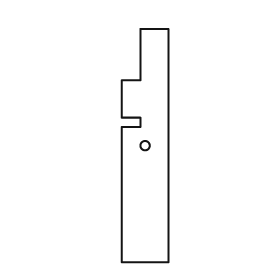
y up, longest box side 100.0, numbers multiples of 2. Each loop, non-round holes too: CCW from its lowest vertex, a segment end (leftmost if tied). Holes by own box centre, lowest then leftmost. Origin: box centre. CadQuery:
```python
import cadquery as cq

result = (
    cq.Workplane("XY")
    .moveTo(-10.0, -50.0)
    .lineTo(10.0, -50.0)
    .lineTo(10.0, 50.0)
    .lineTo(-2.0, 50.0)
    .lineTo(-2.0, 28.0)
    .lineTo(-10.0, 28.0)
    .lineTo(-10.0, 12.0)
    .lineTo(-2.0, 12.0)
    .lineTo(-2.0, 8.0)
    .lineTo(-10.0, 8.0)
    .close()
    .moveTo(0.0, 0.0)
    .circle(2.0)
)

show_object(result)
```